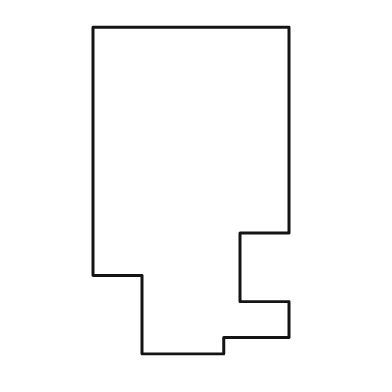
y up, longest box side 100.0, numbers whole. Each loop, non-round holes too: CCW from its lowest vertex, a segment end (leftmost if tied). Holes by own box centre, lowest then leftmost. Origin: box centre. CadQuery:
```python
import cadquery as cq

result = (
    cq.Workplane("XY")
    .moveTo(-15.0, -50.0)
    .lineTo(10.0, -50.0)
    .lineTo(10.0, -45.0)
    .lineTo(30.0, -45.0)
    .lineTo(30.0, -34.0)
    .lineTo(15.0, -34.0)
    .lineTo(15.0, -13.0)
    .lineTo(30.0, -13.0)
    .lineTo(30.0, 50.0)
    .lineTo(-30.0, 50.0)
    .lineTo(-30.0, -26.0)
    .lineTo(-15.0, -26.0)
    .close()
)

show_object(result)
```